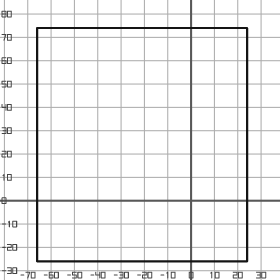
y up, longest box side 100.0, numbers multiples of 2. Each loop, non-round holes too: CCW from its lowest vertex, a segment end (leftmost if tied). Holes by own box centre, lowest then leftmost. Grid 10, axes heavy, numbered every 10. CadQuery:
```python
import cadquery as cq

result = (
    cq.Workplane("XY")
    .moveTo(-66.0, -26.0)
    .lineTo(24.0, -26.0)
    .lineTo(24.0, 74.0)
    .lineTo(-66.0, 74.0)
    .close()
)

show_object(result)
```